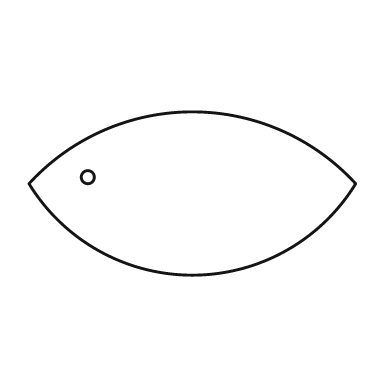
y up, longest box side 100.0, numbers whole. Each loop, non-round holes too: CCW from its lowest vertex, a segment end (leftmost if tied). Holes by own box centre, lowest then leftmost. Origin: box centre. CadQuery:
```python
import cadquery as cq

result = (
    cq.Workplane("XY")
    .moveTo(-50.0, 3.0)
    .threePointArc((0.0, -25.0), (50.0, 3.0))
    .threePointArc((0.0, 25.0), (-50.0, 3.0))
    .close()
    .moveTo(-32.0, 5.0)
    .circle(2.0)
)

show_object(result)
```